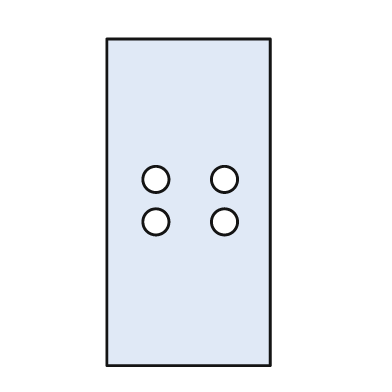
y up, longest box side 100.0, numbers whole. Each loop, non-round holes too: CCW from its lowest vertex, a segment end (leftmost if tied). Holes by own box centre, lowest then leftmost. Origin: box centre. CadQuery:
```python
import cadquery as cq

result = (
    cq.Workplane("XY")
    .moveTo(-25.0, -50.0)
    .lineTo(25.0, -50.0)
    .lineTo(25.0, 50.0)
    .lineTo(-25.0, 50.0)
    .close()
    .moveTo(-10.0, -6.0)
    .circle(4.0)
    .moveTo(11.0, -6.0)
    .circle(4.0)
    .moveTo(-10.0, 7.0)
    .circle(4.0)
    .moveTo(11.0, 7.0)
    .circle(4.0)
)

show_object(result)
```